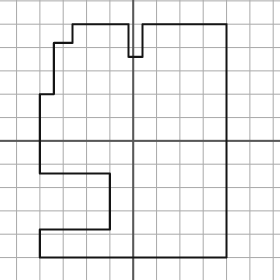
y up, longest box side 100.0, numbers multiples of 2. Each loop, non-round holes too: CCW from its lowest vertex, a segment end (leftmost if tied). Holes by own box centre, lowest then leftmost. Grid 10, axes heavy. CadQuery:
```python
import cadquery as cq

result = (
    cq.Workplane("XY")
    .moveTo(-40.0, -50.0)
    .lineTo(40.0, -50.0)
    .lineTo(40.0, 50.0)
    .lineTo(4.0, 50.0)
    .lineTo(4.0, 36.0)
    .lineTo(-2.0, 36.0)
    .lineTo(-2.0, 50.0)
    .lineTo(-26.0, 50.0)
    .lineTo(-26.0, 42.0)
    .lineTo(-34.0, 42.0)
    .lineTo(-34.0, 20.0)
    .lineTo(-40.0, 20.0)
    .lineTo(-40.0, -14.0)
    .lineTo(-10.0, -14.0)
    .lineTo(-10.0, -38.0)
    .lineTo(-40.0, -38.0)
    .close()
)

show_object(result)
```